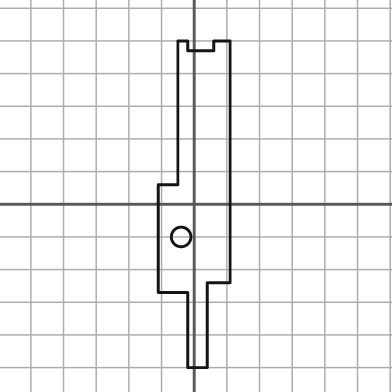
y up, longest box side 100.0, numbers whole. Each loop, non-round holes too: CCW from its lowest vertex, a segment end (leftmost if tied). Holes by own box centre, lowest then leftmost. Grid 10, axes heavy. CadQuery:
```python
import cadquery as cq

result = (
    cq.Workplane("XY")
    .moveTo(-2.0, -50.0)
    .lineTo(4.0, -50.0)
    .lineTo(4.0, -24.0)
    .lineTo(11.0, -24.0)
    .lineTo(11.0, 50.0)
    .lineTo(6.0, 50.0)
    .lineTo(6.0, 47.0)
    .lineTo(-2.0, 47.0)
    .lineTo(-2.0, 50.0)
    .lineTo(-5.0, 50.0)
    .lineTo(-5.0, 6.0)
    .lineTo(-11.0, 6.0)
    .lineTo(-11.0, -27.0)
    .lineTo(-2.0, -27.0)
    .close()
    .moveTo(-4.0, -10.0)
    .circle(3.0)
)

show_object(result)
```